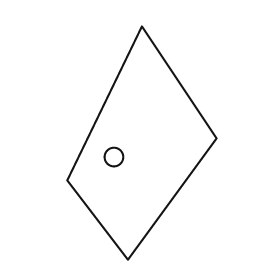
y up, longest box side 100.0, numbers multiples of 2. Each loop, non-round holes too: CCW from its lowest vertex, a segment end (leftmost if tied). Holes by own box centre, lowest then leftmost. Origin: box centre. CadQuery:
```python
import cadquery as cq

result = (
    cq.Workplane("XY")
    .moveTo(-6.0, -50.0)
    .lineTo(32.0, 2.0)
    .lineTo(0.0, 50.0)
    .lineTo(-32.0, -16.0)
    .close()
    .moveTo(-12.0, -6.0)
    .circle(4.0)
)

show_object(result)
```